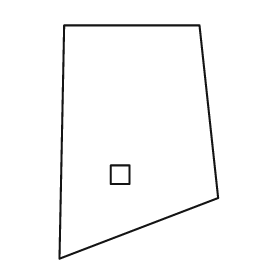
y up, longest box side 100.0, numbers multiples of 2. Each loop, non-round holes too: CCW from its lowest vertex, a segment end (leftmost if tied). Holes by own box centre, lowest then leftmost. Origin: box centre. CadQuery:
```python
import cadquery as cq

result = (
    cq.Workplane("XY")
    .moveTo(-34.0, -50.0)
    .lineTo(34.0, -24.0)
    .lineTo(26.0, 50.0)
    .lineTo(-32.0, 50.0)
    .close()
    .moveTo(-12.0, -18.0)
    .lineTo(-4.0, -18.0)
    .lineTo(-4.0, -10.0)
    .lineTo(-12.0, -10.0)
    .close()
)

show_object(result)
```